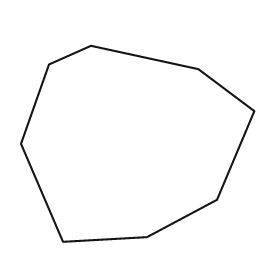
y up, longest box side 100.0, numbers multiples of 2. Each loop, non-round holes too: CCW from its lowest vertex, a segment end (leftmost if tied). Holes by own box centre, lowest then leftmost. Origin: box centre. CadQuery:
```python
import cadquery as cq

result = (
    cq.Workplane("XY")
    .moveTo(-32.0, -42.0)
    .lineTo(4.0, -40.0)
    .lineTo(34.0, -24.0)
    .lineTo(50.0, 14.0)
    .lineTo(26.0, 32.0)
    .lineTo(-20.0, 42.0)
    .lineTo(-38.0, 34.0)
    .lineTo(-50.0, 0.0)
    .close()
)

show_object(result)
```